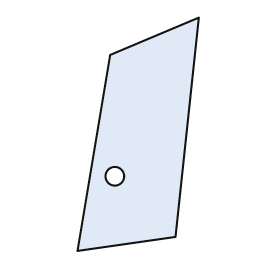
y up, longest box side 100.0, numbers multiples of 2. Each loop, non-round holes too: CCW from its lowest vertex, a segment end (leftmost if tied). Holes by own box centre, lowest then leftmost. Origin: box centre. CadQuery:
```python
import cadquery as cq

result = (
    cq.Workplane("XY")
    .moveTo(-26.0, -50.0)
    .lineTo(16.0, -44.0)
    .lineTo(26.0, 50.0)
    .lineTo(-12.0, 34.0)
    .close()
    .moveTo(-10.0, -18.0)
    .circle(4.0)
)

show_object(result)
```